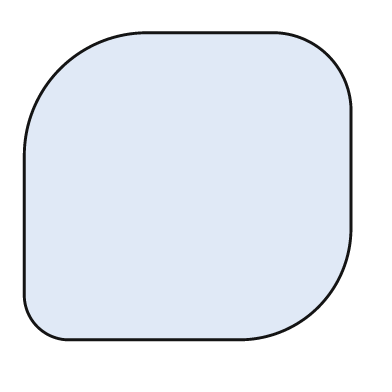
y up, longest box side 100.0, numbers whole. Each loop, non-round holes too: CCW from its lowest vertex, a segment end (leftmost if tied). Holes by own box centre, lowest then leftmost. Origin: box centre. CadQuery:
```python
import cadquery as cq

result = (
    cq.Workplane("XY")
    .moveTo(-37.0, -47.0)
    .lineTo(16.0, -47.0)
    .threePointArc((40.0, -37.0), (50.0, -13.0))
    .lineTo(50.0, 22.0)
    .threePointArc((43.0, 40.0), (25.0, 47.0))
    .lineTo(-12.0, 47.0)
    .threePointArc((-39.0, 36.0), (-50.0, 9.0))
    .lineTo(-50.0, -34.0)
    .threePointArc((-46.0, -43.0), (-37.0, -47.0))
    .close()
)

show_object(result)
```